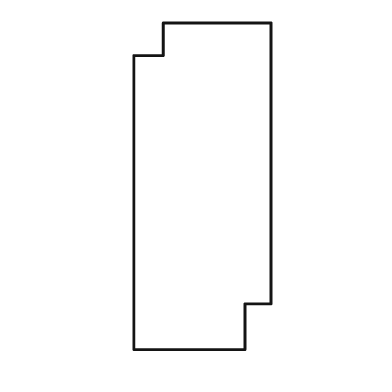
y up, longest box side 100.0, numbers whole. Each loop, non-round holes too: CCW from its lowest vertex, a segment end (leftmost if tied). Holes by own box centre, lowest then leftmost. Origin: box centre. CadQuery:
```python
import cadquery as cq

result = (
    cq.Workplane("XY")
    .moveTo(-21.0, -50.0)
    .lineTo(13.0, -50.0)
    .lineTo(13.0, -36.0)
    .lineTo(21.0, -36.0)
    .lineTo(21.0, 50.0)
    .lineTo(-12.0, 50.0)
    .lineTo(-12.0, 40.0)
    .lineTo(-21.0, 40.0)
    .close()
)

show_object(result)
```